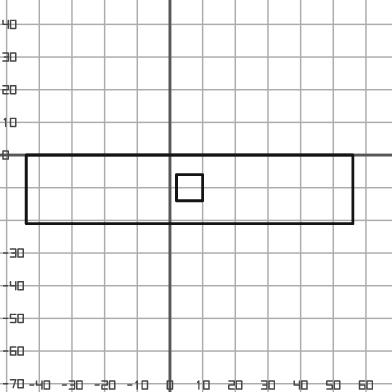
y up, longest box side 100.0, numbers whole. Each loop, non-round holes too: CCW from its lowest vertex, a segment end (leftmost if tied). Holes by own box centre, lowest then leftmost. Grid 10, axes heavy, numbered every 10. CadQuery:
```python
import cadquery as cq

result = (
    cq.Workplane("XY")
    .moveTo(-44.0, -21.0)
    .lineTo(56.0, -21.0)
    .lineTo(56.0, 0.0)
    .lineTo(-44.0, 0.0)
    .close()
    .moveTo(2.0, -14.0)
    .lineTo(10.0, -14.0)
    .lineTo(10.0, -6.0)
    .lineTo(2.0, -6.0)
    .close()
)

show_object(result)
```